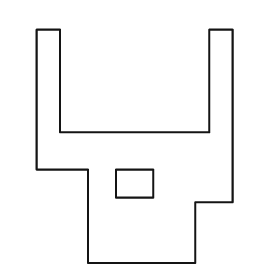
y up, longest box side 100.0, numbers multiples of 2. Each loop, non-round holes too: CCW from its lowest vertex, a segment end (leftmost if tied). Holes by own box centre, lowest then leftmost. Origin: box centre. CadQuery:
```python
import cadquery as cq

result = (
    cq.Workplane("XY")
    .moveTo(-20.0, -50.0)
    .lineTo(26.0, -50.0)
    .lineTo(26.0, -24.0)
    .lineTo(42.0, -24.0)
    .lineTo(42.0, 50.0)
    .lineTo(32.0, 50.0)
    .lineTo(32.0, 6.0)
    .lineTo(-32.0, 6.0)
    .lineTo(-32.0, 50.0)
    .lineTo(-42.0, 50.0)
    .lineTo(-42.0, -10.0)
    .lineTo(-20.0, -10.0)
    .close()
    .moveTo(-8.0, -22.0)
    .lineTo(8.0, -22.0)
    .lineTo(8.0, -10.0)
    .lineTo(-8.0, -10.0)
    .close()
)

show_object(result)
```